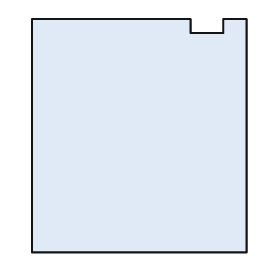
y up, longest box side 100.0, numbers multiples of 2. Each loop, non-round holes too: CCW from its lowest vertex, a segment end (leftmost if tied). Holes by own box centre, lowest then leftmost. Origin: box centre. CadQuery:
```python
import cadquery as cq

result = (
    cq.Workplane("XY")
    .moveTo(-46.0, -50.0)
    .lineTo(46.0, -50.0)
    .lineTo(46.0, 50.0)
    .lineTo(36.0, 50.0)
    .lineTo(36.0, 44.0)
    .lineTo(22.0, 44.0)
    .lineTo(22.0, 50.0)
    .lineTo(-46.0, 50.0)
    .close()
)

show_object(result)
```